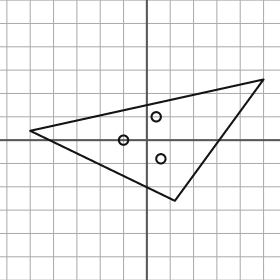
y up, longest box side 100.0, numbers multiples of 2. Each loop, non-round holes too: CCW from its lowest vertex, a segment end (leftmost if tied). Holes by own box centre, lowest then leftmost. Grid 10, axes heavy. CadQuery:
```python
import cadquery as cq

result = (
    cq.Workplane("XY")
    .moveTo(12.0, -26.0)
    .lineTo(50.0, 26.0)
    .lineTo(-50.0, 4.0)
    .close()
    .moveTo(6.0, -8.0)
    .circle(2.0)
    .moveTo(-10.0, 0.0)
    .circle(2.0)
    .moveTo(4.0, 10.0)
    .circle(2.0)
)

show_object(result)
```